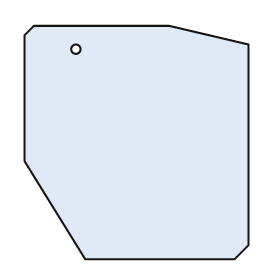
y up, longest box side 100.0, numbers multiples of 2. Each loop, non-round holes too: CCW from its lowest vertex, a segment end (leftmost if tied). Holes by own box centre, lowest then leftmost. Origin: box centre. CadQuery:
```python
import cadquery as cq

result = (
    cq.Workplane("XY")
    .moveTo(-22.0, -50.0)
    .lineTo(42.0, -50.0)
    .lineTo(48.0, -44.0)
    .lineTo(48.0, 42.0)
    .lineTo(14.0, 50.0)
    .lineTo(-44.0, 50.0)
    .lineTo(-48.0, 46.0)
    .lineTo(-48.0, -8.0)
    .close()
    .moveTo(-26.0, 40.0)
    .circle(2.0)
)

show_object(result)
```